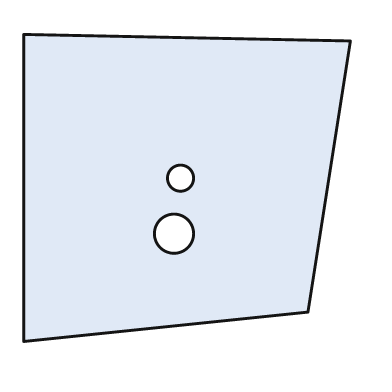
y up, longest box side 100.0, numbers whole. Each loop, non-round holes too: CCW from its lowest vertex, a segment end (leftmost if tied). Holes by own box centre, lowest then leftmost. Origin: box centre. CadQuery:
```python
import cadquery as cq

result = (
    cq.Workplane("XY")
    .moveTo(-50.0, -47.0)
    .lineTo(37.0, -38.0)
    .lineTo(50.0, 45.0)
    .lineTo(-50.0, 47.0)
    .close()
    .moveTo(-4.0, -14.0)
    .circle(6.0)
    .moveTo(-2.0, 3.0)
    .circle(4.0)
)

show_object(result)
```